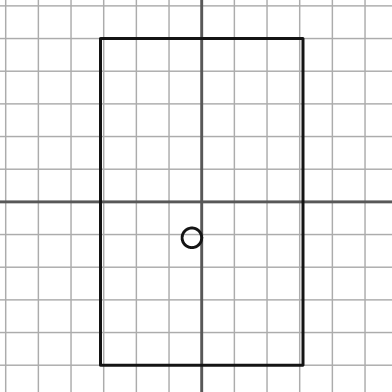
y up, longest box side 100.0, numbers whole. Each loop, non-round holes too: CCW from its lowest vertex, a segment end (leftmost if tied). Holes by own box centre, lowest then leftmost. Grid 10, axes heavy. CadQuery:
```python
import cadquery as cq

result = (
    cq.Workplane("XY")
    .moveTo(-31.0, -50.0)
    .lineTo(31.0, -50.0)
    .lineTo(31.0, 50.0)
    .lineTo(-31.0, 50.0)
    .close()
    .moveTo(-3.0, -11.0)
    .circle(3.0)
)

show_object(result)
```